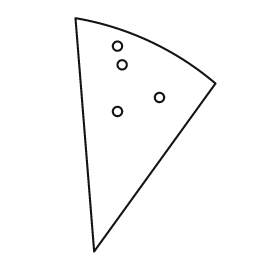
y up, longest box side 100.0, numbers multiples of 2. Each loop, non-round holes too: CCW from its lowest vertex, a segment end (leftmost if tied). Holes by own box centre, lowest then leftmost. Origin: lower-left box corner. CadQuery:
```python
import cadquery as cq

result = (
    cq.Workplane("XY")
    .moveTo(8.0, 0.0)
    .lineTo(60.0, 72.0)
    .threePointArc((32.0, 90.0), (0.0, 100.0))
    .close()
    .moveTo(18.0, 60.0)
    .circle(2.0)
    .moveTo(36.0, 66.0)
    .circle(2.0)
    .moveTo(20.0, 80.0)
    .circle(2.0)
    .moveTo(18.0, 88.0)
    .circle(2.0)
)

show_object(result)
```